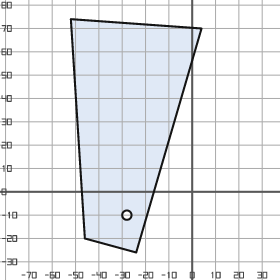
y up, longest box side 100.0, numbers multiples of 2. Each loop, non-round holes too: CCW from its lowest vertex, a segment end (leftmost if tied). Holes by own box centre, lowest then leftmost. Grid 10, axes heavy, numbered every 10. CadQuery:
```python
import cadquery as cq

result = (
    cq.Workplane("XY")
    .moveTo(-24.0, -26.0)
    .lineTo(4.0, 70.0)
    .lineTo(-52.0, 74.0)
    .lineTo(-46.0, -20.0)
    .close()
    .moveTo(-28.0, -10.0)
    .circle(2.0)
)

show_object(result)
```